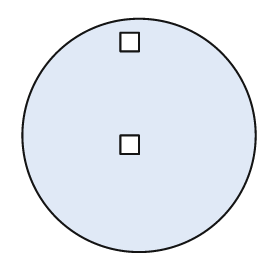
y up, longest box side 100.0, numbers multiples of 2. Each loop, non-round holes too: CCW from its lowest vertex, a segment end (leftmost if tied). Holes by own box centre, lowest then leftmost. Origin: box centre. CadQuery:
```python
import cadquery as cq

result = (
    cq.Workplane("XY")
    .moveTo(0.0, 0.0)
    .circle(50.0)
    .moveTo(-8.0, -8.0)
    .lineTo(0.0, -8.0)
    .lineTo(0.0, 0.0)
    .lineTo(-8.0, 0.0)
    .close()
    .moveTo(-8.0, 36.0)
    .lineTo(0.0, 36.0)
    .lineTo(0.0, 44.0)
    .lineTo(-8.0, 44.0)
    .close()
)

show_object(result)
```